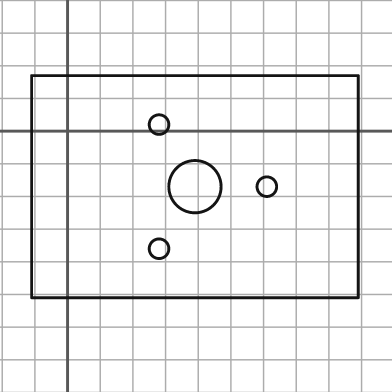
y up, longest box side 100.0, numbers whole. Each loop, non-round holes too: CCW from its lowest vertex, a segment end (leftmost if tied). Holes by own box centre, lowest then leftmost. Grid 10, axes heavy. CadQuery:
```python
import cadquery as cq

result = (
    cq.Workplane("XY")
    .moveTo(-11.0, -51.0)
    .lineTo(89.0, -51.0)
    .lineTo(89.0, 17.0)
    .lineTo(-11.0, 17.0)
    .close()
    .moveTo(28.0, -36.0)
    .circle(3.0)
    .moveTo(39.0, -17.0)
    .circle(8.0)
    .moveTo(61.0, -17.0)
    .circle(3.0)
    .moveTo(28.0, 2.0)
    .circle(3.0)
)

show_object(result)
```